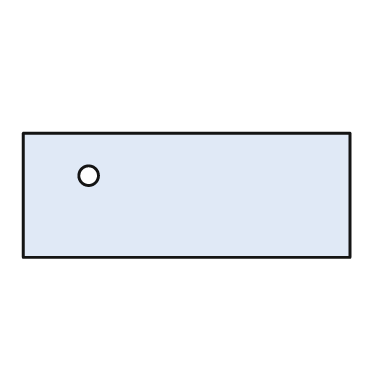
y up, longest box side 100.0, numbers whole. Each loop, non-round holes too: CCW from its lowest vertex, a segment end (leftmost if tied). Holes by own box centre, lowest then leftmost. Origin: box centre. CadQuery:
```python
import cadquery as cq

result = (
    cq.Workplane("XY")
    .moveTo(-50.0, -19.0)
    .lineTo(50.0, -19.0)
    .lineTo(50.0, 19.0)
    .lineTo(-50.0, 19.0)
    .close()
    .moveTo(-30.0, 6.0)
    .circle(3.0)
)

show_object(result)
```